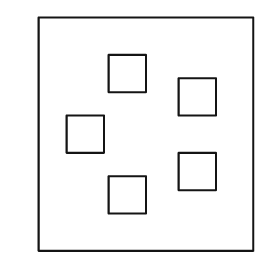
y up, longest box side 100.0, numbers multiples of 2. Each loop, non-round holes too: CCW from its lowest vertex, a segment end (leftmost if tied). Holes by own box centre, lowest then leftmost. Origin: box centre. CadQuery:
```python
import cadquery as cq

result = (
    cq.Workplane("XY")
    .moveTo(-46.0, -50.0)
    .lineTo(46.0, -50.0)
    .lineTo(46.0, 50.0)
    .lineTo(-46.0, 50.0)
    .close()
    .moveTo(-16.0, -34.0)
    .lineTo(0.0, -34.0)
    .lineTo(0.0, -18.0)
    .lineTo(-16.0, -18.0)
    .close()
    .moveTo(14.0, -24.0)
    .lineTo(30.0, -24.0)
    .lineTo(30.0, -8.0)
    .lineTo(14.0, -8.0)
    .close()
    .moveTo(-34.0, -8.0)
    .lineTo(-18.0, -8.0)
    .lineTo(-18.0, 8.0)
    .lineTo(-34.0, 8.0)
    .close()
    .moveTo(14.0, 8.0)
    .lineTo(30.0, 8.0)
    .lineTo(30.0, 24.0)
    .lineTo(14.0, 24.0)
    .close()
    .moveTo(-16.0, 18.0)
    .lineTo(0.0, 18.0)
    .lineTo(0.0, 34.0)
    .lineTo(-16.0, 34.0)
    .close()
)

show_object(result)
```